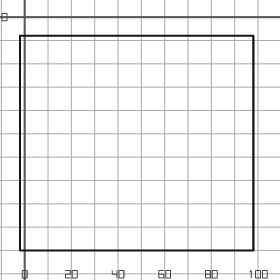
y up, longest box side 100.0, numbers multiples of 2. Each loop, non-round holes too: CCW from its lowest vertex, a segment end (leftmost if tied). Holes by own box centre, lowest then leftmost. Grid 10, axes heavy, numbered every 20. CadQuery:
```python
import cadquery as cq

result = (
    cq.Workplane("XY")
    .moveTo(-2.0, -100.0)
    .lineTo(98.0, -100.0)
    .lineTo(98.0, -8.0)
    .lineTo(-2.0, -8.0)
    .close()
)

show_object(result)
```